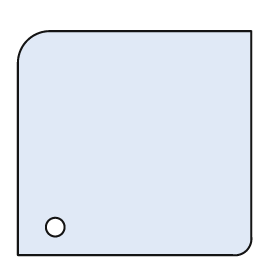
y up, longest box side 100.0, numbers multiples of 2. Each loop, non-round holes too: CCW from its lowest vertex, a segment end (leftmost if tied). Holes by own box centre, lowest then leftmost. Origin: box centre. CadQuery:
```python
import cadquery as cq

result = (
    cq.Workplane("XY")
    .moveTo(-50.0, -48.0)
    .lineTo(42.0, -48.0)
    .threePointArc((48.0, -46.0), (50.0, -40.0))
    .lineTo(50.0, 48.0)
    .lineTo(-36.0, 48.0)
    .threePointArc((-46.0, 44.0), (-50.0, 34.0))
    .close()
    .moveTo(-34.0, -36.0)
    .circle(4.0)
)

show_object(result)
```